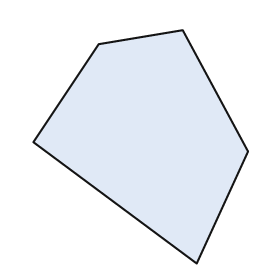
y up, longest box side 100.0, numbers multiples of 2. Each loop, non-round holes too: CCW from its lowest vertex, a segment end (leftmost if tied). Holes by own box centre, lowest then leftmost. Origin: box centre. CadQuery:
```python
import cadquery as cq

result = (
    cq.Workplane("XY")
    .moveTo(24.0, -50.0)
    .lineTo(46.0, -2.0)
    .lineTo(18.0, 50.0)
    .lineTo(-18.0, 44.0)
    .lineTo(-46.0, 2.0)
    .close()
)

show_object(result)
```